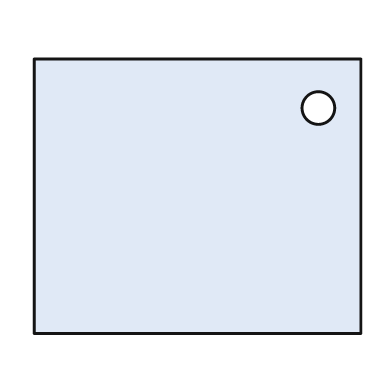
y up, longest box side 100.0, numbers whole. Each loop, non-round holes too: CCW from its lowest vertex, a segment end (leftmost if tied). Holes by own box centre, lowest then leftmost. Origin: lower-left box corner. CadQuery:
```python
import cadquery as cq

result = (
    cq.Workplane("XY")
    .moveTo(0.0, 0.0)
    .lineTo(100.0, 0.0)
    .lineTo(100.0, 84.0)
    .lineTo(0.0, 84.0)
    .close()
    .moveTo(87.0, 69.0)
    .circle(5.0)
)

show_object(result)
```